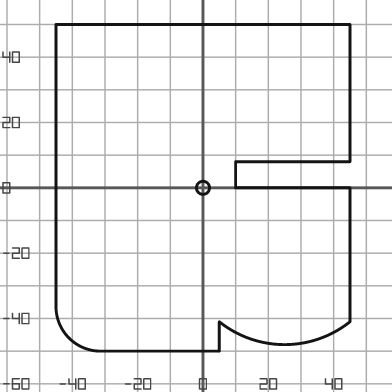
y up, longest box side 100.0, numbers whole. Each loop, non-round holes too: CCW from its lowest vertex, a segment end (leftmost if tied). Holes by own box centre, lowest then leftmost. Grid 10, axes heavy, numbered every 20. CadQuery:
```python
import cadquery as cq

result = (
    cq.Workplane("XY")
    .moveTo(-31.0, -50.0)
    .lineTo(5.0, -50.0)
    .lineTo(5.0, -41.0)
    .threePointArc((25.0, -48.0), (45.0, -41.0))
    .lineTo(45.0, 0.0)
    .lineTo(10.0, 0.0)
    .lineTo(10.0, 8.0)
    .lineTo(45.0, 8.0)
    .lineTo(45.0, 50.0)
    .lineTo(-45.0, 50.0)
    .lineTo(-45.0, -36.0)
    .threePointArc((-41.0, -46.0), (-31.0, -50.0))
    .close()
    .moveTo(0.0, 0.0)
    .circle(2.0)
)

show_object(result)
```